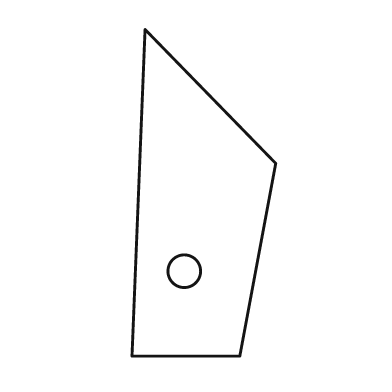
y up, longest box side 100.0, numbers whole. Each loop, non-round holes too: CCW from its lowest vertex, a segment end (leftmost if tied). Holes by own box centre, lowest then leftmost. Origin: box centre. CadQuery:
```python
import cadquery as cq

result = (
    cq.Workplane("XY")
    .moveTo(-22.0, -50.0)
    .lineTo(11.0, -50.0)
    .lineTo(22.0, 9.0)
    .lineTo(-18.0, 50.0)
    .close()
    .moveTo(-6.0, -24.0)
    .circle(5.0)
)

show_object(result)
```